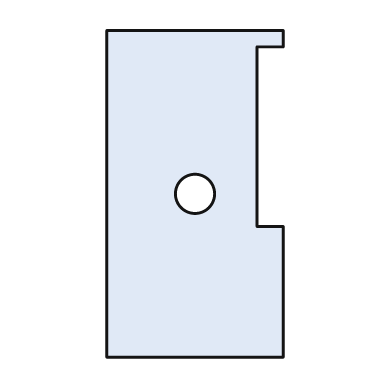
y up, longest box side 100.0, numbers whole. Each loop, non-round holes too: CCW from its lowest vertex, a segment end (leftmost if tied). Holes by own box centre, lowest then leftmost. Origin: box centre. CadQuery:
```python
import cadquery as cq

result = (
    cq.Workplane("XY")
    .moveTo(-27.0, -50.0)
    .lineTo(27.0, -50.0)
    .lineTo(27.0, -10.0)
    .lineTo(19.0, -10.0)
    .lineTo(19.0, 45.0)
    .lineTo(27.0, 45.0)
    .lineTo(27.0, 50.0)
    .lineTo(-27.0, 50.0)
    .close()
    .moveTo(0.0, 0.0)
    .circle(6.0)
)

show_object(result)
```